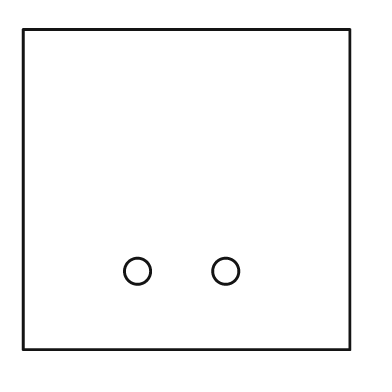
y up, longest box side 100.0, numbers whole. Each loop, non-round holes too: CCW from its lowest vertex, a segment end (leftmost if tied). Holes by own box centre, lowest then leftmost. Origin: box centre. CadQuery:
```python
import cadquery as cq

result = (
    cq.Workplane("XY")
    .moveTo(-50.0, -49.0)
    .lineTo(50.0, -49.0)
    .lineTo(50.0, 49.0)
    .lineTo(-50.0, 49.0)
    .close()
    .moveTo(-15.0, -25.0)
    .circle(4.0)
    .moveTo(12.0, -25.0)
    .circle(4.0)
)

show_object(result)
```